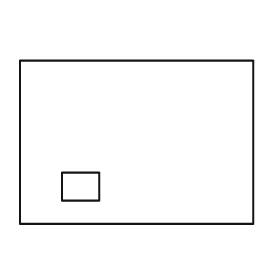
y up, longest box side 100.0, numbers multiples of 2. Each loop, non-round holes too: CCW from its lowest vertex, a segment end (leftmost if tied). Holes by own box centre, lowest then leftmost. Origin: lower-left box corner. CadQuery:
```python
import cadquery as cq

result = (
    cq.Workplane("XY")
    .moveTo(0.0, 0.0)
    .lineTo(100.0, 0.0)
    .lineTo(100.0, 70.0)
    .lineTo(0.0, 70.0)
    .close()
    .moveTo(18.0, 10.0)
    .lineTo(34.0, 10.0)
    .lineTo(34.0, 22.0)
    .lineTo(18.0, 22.0)
    .close()
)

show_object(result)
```